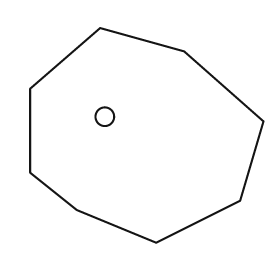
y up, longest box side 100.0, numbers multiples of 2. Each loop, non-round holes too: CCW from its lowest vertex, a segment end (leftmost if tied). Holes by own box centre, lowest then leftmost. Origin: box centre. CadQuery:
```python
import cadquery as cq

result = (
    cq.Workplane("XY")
    .moveTo(4.0, -46.0)
    .lineTo(40.0, -28.0)
    .lineTo(50.0, 6.0)
    .lineTo(16.0, 36.0)
    .lineTo(-20.0, 46.0)
    .lineTo(-50.0, 20.0)
    .lineTo(-50.0, -16.0)
    .lineTo(-30.0, -32.0)
    .close()
    .moveTo(-18.0, 8.0)
    .circle(4.0)
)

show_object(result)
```